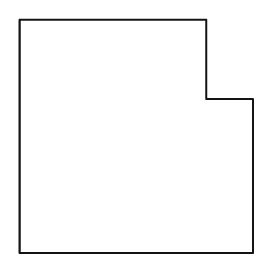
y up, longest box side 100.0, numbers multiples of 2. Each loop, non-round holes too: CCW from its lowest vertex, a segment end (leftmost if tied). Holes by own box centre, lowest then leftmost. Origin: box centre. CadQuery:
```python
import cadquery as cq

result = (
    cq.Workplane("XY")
    .moveTo(-50.0, -50.0)
    .lineTo(50.0, -50.0)
    .lineTo(50.0, 16.0)
    .lineTo(30.0, 16.0)
    .lineTo(30.0, 50.0)
    .lineTo(-50.0, 50.0)
    .close()
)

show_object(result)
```